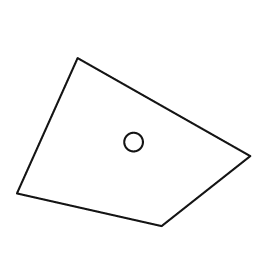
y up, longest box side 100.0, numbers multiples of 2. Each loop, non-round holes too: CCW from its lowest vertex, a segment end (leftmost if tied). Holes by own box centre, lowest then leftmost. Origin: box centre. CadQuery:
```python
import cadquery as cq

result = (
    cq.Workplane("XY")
    .moveTo(12.0, -36.0)
    .lineTo(50.0, -6.0)
    .lineTo(-24.0, 36.0)
    .lineTo(-50.0, -22.0)
    .close()
    .moveTo(0.0, 0.0)
    .circle(4.0)
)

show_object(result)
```